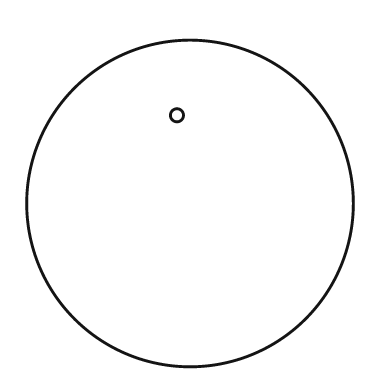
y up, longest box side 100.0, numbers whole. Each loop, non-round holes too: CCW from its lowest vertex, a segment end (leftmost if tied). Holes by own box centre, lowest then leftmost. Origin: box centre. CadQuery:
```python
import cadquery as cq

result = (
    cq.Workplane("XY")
    .moveTo(0.0, 0.0)
    .circle(50.0)
    .moveTo(-4.0, 27.0)
    .circle(2.0)
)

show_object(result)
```